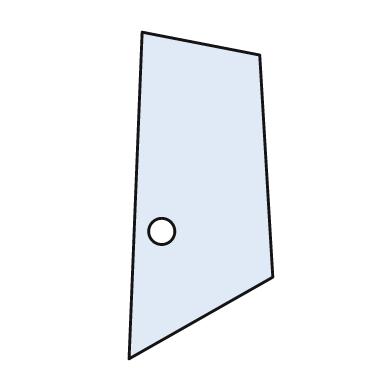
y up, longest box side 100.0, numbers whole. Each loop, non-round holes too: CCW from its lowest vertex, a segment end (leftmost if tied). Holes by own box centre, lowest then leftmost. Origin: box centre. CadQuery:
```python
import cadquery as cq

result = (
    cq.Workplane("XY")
    .moveTo(-22.0, -50.0)
    .lineTo(22.0, -25.0)
    .lineTo(18.0, 43.0)
    .lineTo(-18.0, 50.0)
    .close()
    .moveTo(-12.0, -11.0)
    .circle(4.0)
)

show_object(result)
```